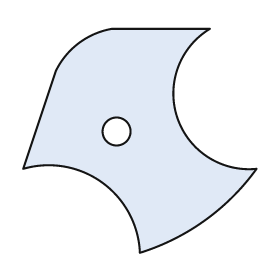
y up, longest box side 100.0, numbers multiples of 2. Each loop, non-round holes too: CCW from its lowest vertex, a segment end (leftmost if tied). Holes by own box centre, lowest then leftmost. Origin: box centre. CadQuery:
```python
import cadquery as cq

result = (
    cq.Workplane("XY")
    .moveTo(0.0, -48.0)
    .threePointArc((28.0, -34.0), (50.0, -12.0))
    .threePointArc((16.0, 10.0), (30.0, 48.0))
    .lineTo(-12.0, 48.0)
    .threePointArc((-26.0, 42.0), (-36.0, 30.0))
    .lineTo(-50.0, -12.0)
    .threePointArc((-16.0, -18.0), (0.0, -48.0))
    .close()
    .moveTo(-10.0, 4.0)
    .circle(6.0)
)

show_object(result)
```